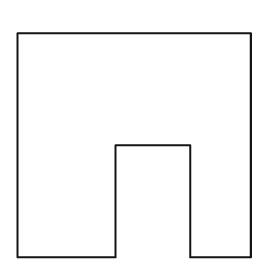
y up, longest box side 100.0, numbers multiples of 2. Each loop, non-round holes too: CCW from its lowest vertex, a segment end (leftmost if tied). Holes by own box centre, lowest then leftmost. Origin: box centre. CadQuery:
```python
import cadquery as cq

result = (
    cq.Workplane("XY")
    .moveTo(-50.0, -48.0)
    .lineTo(-8.0, -48.0)
    .lineTo(-8.0, 0.0)
    .lineTo(24.0, 0.0)
    .lineTo(24.0, -48.0)
    .lineTo(50.0, -48.0)
    .lineTo(50.0, 48.0)
    .lineTo(-50.0, 48.0)
    .close()
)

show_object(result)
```